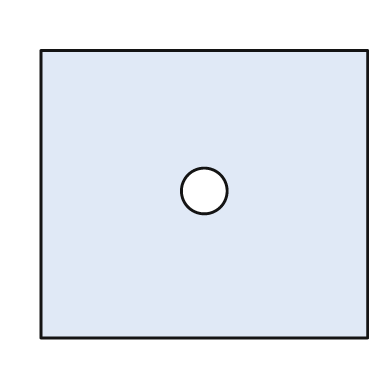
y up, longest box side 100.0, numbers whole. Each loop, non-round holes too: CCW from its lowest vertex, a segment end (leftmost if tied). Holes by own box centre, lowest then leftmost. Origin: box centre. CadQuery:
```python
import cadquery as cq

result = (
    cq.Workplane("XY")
    .moveTo(-50.0, -44.0)
    .lineTo(50.0, -44.0)
    .lineTo(50.0, 44.0)
    .lineTo(-50.0, 44.0)
    .close()
    .moveTo(0.0, 1.0)
    .circle(7.0)
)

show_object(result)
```